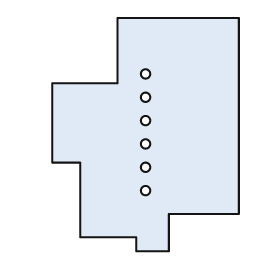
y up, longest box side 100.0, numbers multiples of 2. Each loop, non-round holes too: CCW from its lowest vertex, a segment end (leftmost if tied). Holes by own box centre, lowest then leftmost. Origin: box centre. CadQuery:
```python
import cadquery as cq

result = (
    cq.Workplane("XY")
    .moveTo(-4.0, -50.0)
    .lineTo(10.0, -50.0)
    .lineTo(10.0, -34.0)
    .lineTo(40.0, -34.0)
    .lineTo(40.0, 50.0)
    .lineTo(-12.0, 50.0)
    .lineTo(-12.0, 22.0)
    .lineTo(-40.0, 22.0)
    .lineTo(-40.0, -12.0)
    .lineTo(-28.0, -12.0)
    .lineTo(-28.0, -44.0)
    .lineTo(-4.0, -44.0)
    .close()
    .moveTo(0.0, -24.0)
    .circle(2.0)
    .moveTo(0.0, -14.0)
    .circle(2.0)
    .moveTo(0.0, -4.0)
    .circle(2.0)
    .moveTo(0.0, 6.0)
    .circle(2.0)
    .moveTo(0.0, 16.0)
    .circle(2.0)
    .moveTo(0.0, 26.0)
    .circle(2.0)
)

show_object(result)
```